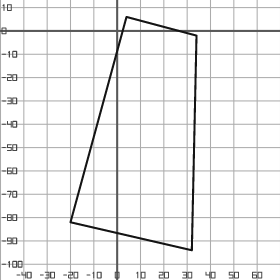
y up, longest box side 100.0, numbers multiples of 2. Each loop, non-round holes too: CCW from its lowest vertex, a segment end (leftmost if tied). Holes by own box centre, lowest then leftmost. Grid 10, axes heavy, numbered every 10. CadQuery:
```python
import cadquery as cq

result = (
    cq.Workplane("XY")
    .moveTo(32.0, -94.0)
    .lineTo(34.0, -2.0)
    .lineTo(4.0, 6.0)
    .lineTo(-20.0, -82.0)
    .close()
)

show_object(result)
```